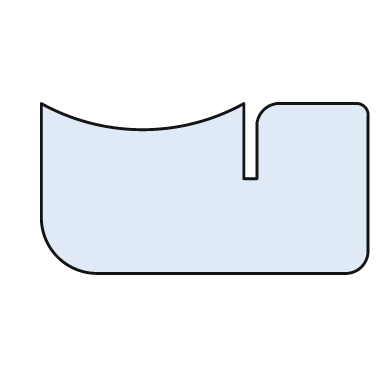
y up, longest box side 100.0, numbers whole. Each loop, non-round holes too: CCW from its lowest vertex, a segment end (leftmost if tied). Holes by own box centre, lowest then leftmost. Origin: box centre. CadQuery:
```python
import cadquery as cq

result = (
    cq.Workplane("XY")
    .moveTo(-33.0, -26.0)
    .lineTo(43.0, -26.0)
    .threePointArc((48.0, -24.0), (50.0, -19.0))
    .lineTo(50.0, 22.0)
    .threePointArc((49.0, 25.0), (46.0, 26.0))
    .lineTo(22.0, 26.0)
    .threePointArc((18.0, 24.0), (16.0, 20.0))
    .lineTo(16.0, 3.0)
    .lineTo(12.0, 3.0)
    .lineTo(12.0, 26.0)
    .threePointArc((-19.0, 18.0), (-50.0, 26.0))
    .lineTo(-50.0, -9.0)
    .threePointArc((-45.0, -21.0), (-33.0, -26.0))
    .close()
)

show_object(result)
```